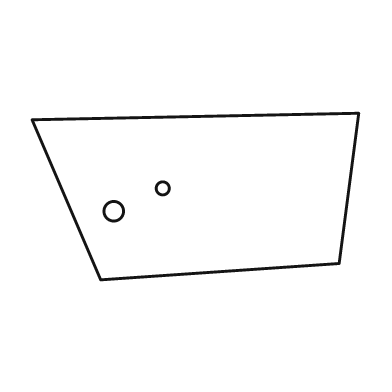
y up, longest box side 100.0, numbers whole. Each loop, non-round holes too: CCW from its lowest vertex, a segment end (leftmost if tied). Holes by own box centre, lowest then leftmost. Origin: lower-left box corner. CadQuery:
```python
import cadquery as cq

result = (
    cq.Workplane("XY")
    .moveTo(21.0, 0.0)
    .lineTo(94.0, 5.0)
    .lineTo(100.0, 51.0)
    .lineTo(0.0, 49.0)
    .close()
    .moveTo(25.0, 21.0)
    .circle(3.0)
    .moveTo(40.0, 28.0)
    .circle(2.0)
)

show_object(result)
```